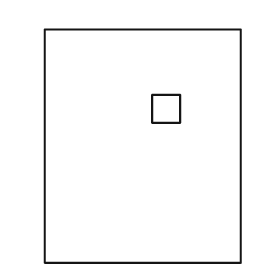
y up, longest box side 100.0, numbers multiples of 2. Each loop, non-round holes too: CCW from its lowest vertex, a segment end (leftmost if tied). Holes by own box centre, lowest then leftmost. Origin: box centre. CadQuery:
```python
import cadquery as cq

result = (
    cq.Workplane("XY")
    .moveTo(-42.0, -50.0)
    .lineTo(42.0, -50.0)
    .lineTo(42.0, 50.0)
    .lineTo(-42.0, 50.0)
    .close()
    .moveTo(4.0, 10.0)
    .lineTo(16.0, 10.0)
    .lineTo(16.0, 22.0)
    .lineTo(4.0, 22.0)
    .close()
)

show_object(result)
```